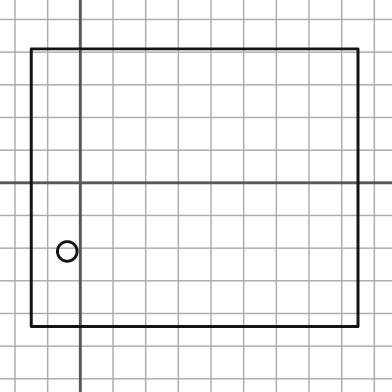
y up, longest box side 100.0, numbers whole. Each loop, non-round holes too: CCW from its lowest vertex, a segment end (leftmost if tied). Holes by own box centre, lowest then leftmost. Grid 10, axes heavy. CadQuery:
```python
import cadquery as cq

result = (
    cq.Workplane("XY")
    .moveTo(-15.0, -44.0)
    .lineTo(85.0, -44.0)
    .lineTo(85.0, 41.0)
    .lineTo(-15.0, 41.0)
    .close()
    .moveTo(-4.0, -21.0)
    .circle(3.0)
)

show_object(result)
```